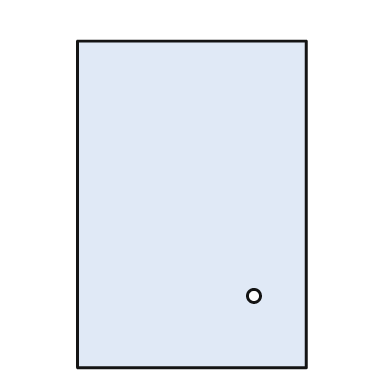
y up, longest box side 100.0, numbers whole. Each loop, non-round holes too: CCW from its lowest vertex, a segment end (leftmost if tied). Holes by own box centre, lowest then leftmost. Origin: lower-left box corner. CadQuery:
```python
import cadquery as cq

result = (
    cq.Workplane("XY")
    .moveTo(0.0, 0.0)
    .lineTo(70.0, 0.0)
    .lineTo(70.0, 100.0)
    .lineTo(0.0, 100.0)
    .close()
    .moveTo(54.0, 22.0)
    .circle(2.0)
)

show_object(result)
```